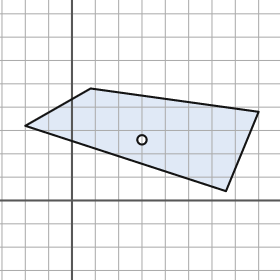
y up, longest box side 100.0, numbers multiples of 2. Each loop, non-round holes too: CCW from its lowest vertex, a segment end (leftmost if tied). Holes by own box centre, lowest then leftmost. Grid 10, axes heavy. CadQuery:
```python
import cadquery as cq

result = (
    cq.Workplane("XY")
    .moveTo(66.0, 4.0)
    .lineTo(80.0, 38.0)
    .lineTo(8.0, 48.0)
    .lineTo(-20.0, 32.0)
    .close()
    .moveTo(30.0, 26.0)
    .circle(2.0)
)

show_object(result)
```